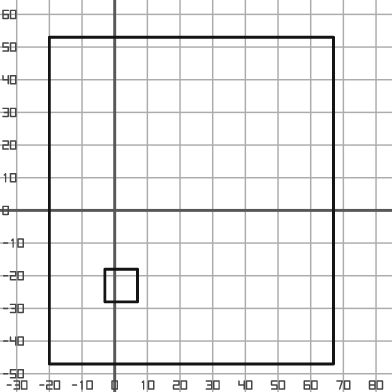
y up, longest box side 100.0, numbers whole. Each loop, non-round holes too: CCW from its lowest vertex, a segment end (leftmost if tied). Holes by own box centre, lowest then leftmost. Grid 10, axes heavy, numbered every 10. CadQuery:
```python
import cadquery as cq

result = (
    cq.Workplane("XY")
    .moveTo(-20.0, -47.0)
    .lineTo(67.0, -47.0)
    .lineTo(67.0, 53.0)
    .lineTo(-20.0, 53.0)
    .close()
    .moveTo(-3.0, -28.0)
    .lineTo(7.0, -28.0)
    .lineTo(7.0, -18.0)
    .lineTo(-3.0, -18.0)
    .close()
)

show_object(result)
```